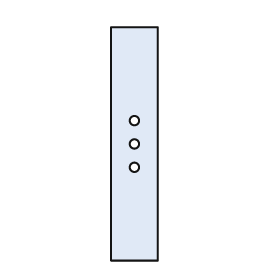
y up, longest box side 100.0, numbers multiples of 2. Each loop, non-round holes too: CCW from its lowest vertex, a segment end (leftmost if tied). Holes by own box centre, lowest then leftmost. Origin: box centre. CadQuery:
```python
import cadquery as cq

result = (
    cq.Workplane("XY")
    .moveTo(-10.0, -50.0)
    .lineTo(10.0, -50.0)
    .lineTo(10.0, 50.0)
    .lineTo(-10.0, 50.0)
    .close()
    .moveTo(0.0, -10.0)
    .circle(2.0)
    .moveTo(0.0, 0.0)
    .circle(2.0)
    .moveTo(0.0, 10.0)
    .circle(2.0)
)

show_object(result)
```